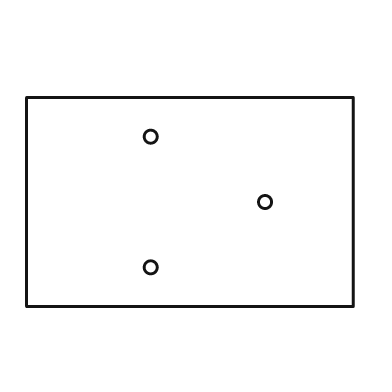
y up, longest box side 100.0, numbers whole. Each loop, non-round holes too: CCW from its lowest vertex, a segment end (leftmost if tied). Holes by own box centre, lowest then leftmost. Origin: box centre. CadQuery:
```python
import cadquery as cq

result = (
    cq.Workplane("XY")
    .moveTo(-50.0, -32.0)
    .lineTo(50.0, -32.0)
    .lineTo(50.0, 32.0)
    .lineTo(-50.0, 32.0)
    .close()
    .moveTo(-12.0, -20.0)
    .circle(2.0)
    .moveTo(23.0, 0.0)
    .circle(2.0)
    .moveTo(-12.0, 20.0)
    .circle(2.0)
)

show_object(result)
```